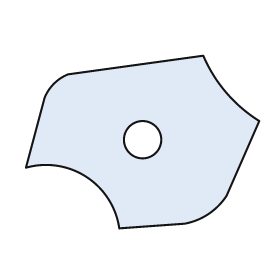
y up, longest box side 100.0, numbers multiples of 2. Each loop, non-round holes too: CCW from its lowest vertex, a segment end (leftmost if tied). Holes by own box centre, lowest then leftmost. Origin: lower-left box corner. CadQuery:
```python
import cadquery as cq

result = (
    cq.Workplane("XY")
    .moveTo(40.0, 0.0)
    .lineTo(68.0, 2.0)
    .threePointArc((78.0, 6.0), (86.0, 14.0))
    .lineTo(100.0, 46.0)
    .threePointArc((86.0, 58.0), (76.0, 74.0))
    .lineTo(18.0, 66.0)
    .threePointArc((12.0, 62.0), (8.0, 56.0))
    .lineTo(0.0, 26.0)
    .threePointArc((26.0, 22.0), (40.0, 0.0))
    .close()
    .moveTo(50.0, 38.0)
    .circle(8.0)
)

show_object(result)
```